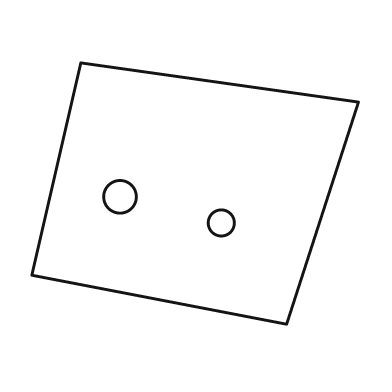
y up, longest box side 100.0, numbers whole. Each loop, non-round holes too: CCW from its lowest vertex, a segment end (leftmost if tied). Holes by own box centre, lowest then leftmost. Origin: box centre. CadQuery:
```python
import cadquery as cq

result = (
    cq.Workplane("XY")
    .moveTo(28.0, -40.0)
    .lineTo(50.0, 28.0)
    .lineTo(-35.0, 40.0)
    .lineTo(-50.0, -25.0)
    .close()
    .moveTo(8.0, -9.0)
    .circle(4.0)
    .moveTo(-23.0, -1.0)
    .circle(5.0)
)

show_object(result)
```